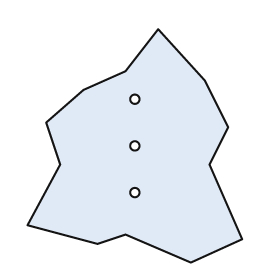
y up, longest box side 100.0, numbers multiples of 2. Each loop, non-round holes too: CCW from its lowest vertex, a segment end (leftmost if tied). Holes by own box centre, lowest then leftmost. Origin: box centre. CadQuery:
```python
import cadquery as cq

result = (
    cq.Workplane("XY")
    .moveTo(24.0, -50.0)
    .lineTo(46.0, -40.0)
    .lineTo(32.0, -8.0)
    .lineTo(40.0, 8.0)
    .lineTo(30.0, 28.0)
    .lineTo(10.0, 50.0)
    .lineTo(-4.0, 32.0)
    .lineTo(-22.0, 24.0)
    .lineTo(-38.0, 10.0)
    .lineTo(-32.0, -8.0)
    .lineTo(-46.0, -34.0)
    .lineTo(-16.0, -42.0)
    .lineTo(-4.0, -38.0)
    .close()
    .moveTo(0.0, -20.0)
    .circle(2.0)
    .moveTo(0.0, 0.0)
    .circle(2.0)
    .moveTo(0.0, 20.0)
    .circle(2.0)
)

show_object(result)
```